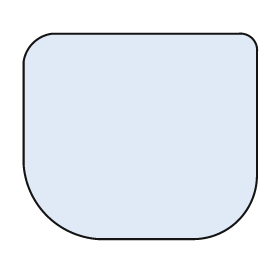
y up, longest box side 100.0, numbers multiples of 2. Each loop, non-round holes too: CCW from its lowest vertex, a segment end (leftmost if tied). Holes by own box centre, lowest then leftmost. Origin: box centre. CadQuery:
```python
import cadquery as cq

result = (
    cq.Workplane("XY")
    .moveTo(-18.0, -44.0)
    .lineTo(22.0, -44.0)
    .threePointArc((42.0, -36.0), (50.0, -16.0))
    .lineTo(50.0, 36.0)
    .threePointArc((48.0, 42.0), (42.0, 44.0))
    .lineTo(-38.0, 44.0)
    .threePointArc((-46.0, 40.0), (-50.0, 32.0))
    .lineTo(-50.0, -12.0)
    .threePointArc((-40.0, -34.0), (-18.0, -44.0))
    .close()
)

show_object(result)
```